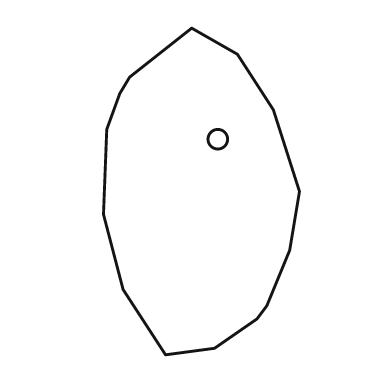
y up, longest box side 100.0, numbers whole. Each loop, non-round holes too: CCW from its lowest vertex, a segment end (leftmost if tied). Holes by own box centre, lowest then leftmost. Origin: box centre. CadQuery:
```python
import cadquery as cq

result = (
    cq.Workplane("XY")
    .moveTo(-11.0, -50.0)
    .lineTo(4.0, -48.0)
    .lineTo(17.0, -39.0)
    .lineTo(20.0, -35.0)
    .lineTo(27.0, -18.0)
    .lineTo(30.0, 0.0)
    .lineTo(22.0, 25.0)
    .lineTo(11.0, 42.0)
    .lineTo(-3.0, 50.0)
    .lineTo(-22.0, 35.0)
    .lineTo(-25.0, 30.0)
    .lineTo(-29.0, 19.0)
    .lineTo(-30.0, -7.0)
    .lineTo(-24.0, -30.0)
    .close()
    .moveTo(5.0, 16.0)
    .circle(3.0)
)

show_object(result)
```